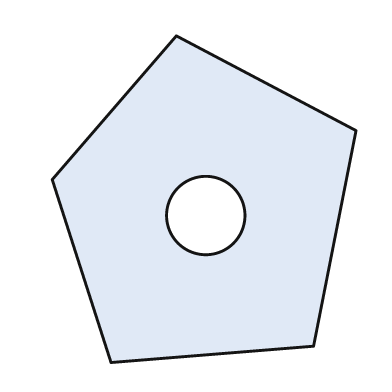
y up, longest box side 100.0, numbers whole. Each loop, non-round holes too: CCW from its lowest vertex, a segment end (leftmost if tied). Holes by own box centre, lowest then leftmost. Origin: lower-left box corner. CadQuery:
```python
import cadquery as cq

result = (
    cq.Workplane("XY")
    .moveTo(18.0, 0.0)
    .lineTo(80.0, 5.0)
    .lineTo(93.0, 71.0)
    .lineTo(38.0, 100.0)
    .lineTo(0.0, 56.0)
    .close()
    .moveTo(47.0, 45.0)
    .circle(12.0)
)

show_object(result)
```